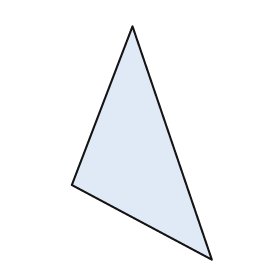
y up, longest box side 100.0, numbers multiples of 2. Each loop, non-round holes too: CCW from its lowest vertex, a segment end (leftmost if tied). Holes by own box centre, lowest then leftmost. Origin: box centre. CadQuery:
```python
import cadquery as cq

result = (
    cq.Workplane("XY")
    .moveTo(30.0, -50.0)
    .lineTo(-4.0, 50.0)
    .lineTo(-30.0, -18.0)
    .close()
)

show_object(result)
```